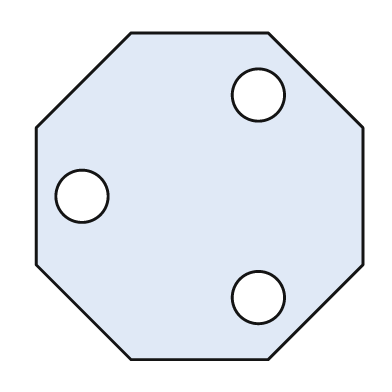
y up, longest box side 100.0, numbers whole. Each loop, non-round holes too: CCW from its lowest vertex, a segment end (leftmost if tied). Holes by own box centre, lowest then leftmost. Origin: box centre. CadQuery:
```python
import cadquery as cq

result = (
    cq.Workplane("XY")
    .moveTo(-21.0, -50.0)
    .lineTo(21.0, -50.0)
    .lineTo(50.0, -21.0)
    .lineTo(50.0, 21.0)
    .lineTo(21.0, 50.0)
    .lineTo(-21.0, 50.0)
    .lineTo(-50.0, 21.0)
    .lineTo(-50.0, -21.0)
    .close()
    .moveTo(18.0, -31.0)
    .circle(8.0)
    .moveTo(-36.0, 0.0)
    .circle(8.0)
    .moveTo(18.0, 31.0)
    .circle(8.0)
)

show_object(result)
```